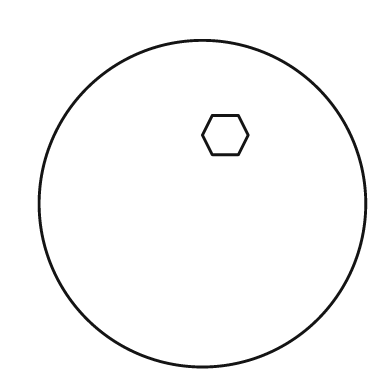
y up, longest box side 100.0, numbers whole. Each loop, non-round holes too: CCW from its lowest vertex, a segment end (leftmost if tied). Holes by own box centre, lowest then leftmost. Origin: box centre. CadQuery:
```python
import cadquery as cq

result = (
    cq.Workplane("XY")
    .moveTo(0.0, 0.0)
    .circle(50.0)
    .moveTo(3.0, 15.0)
    .lineTo(11.0, 15.0)
    .lineTo(14.0, 21.0)
    .lineTo(11.0, 27.0)
    .lineTo(3.0, 27.0)
    .lineTo(0.0, 21.0)
    .close()
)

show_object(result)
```